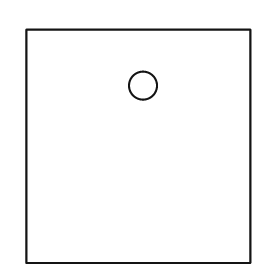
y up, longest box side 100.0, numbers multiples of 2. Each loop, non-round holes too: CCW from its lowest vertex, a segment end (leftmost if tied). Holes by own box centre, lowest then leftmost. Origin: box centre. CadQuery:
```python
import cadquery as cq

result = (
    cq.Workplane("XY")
    .moveTo(-48.0, -50.0)
    .lineTo(48.0, -50.0)
    .lineTo(48.0, 50.0)
    .lineTo(-48.0, 50.0)
    .close()
    .moveTo(2.0, 26.0)
    .circle(6.0)
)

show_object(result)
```